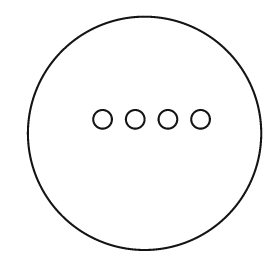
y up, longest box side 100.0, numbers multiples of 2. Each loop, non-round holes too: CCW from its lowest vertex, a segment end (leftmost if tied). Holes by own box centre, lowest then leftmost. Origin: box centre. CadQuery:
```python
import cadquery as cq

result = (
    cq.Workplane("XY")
    .moveTo(0.0, 0.0)
    .circle(50.0)
    .moveTo(-18.0, 6.0)
    .circle(4.0)
    .moveTo(-4.0, 6.0)
    .circle(4.0)
    .moveTo(10.0, 6.0)
    .circle(4.0)
    .moveTo(24.0, 6.0)
    .circle(4.0)
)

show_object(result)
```